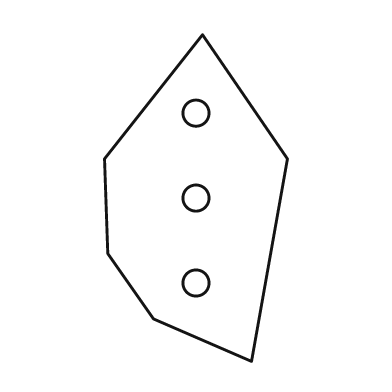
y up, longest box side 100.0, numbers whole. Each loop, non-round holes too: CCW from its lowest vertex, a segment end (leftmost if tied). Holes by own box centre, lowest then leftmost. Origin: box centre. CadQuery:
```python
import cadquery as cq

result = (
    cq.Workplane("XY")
    .moveTo(17.0, -50.0)
    .lineTo(28.0, 12.0)
    .lineTo(2.0, 50.0)
    .lineTo(-28.0, 12.0)
    .lineTo(-27.0, -17.0)
    .lineTo(-13.0, -37.0)
    .close()
    .moveTo(0.0, -26.0)
    .circle(4.0)
    .moveTo(0.0, 0.0)
    .circle(4.0)
    .moveTo(0.0, 26.0)
    .circle(4.0)
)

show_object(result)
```